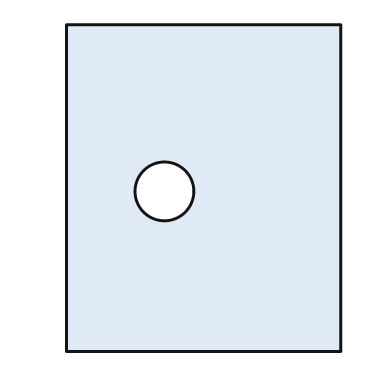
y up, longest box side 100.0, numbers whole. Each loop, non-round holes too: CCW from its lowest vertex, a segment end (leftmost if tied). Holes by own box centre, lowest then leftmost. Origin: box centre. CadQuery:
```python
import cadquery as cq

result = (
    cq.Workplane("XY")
    .moveTo(-42.0, -50.0)
    .lineTo(42.0, -50.0)
    .lineTo(42.0, 50.0)
    .lineTo(-42.0, 50.0)
    .close()
    .moveTo(-12.0, -1.0)
    .circle(9.0)
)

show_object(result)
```